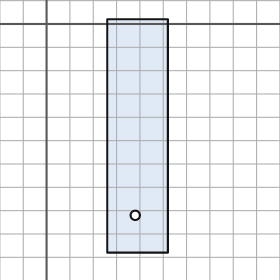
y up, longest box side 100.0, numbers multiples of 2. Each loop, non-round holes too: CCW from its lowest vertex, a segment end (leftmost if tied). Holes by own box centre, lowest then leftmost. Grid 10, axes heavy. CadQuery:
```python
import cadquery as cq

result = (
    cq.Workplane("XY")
    .moveTo(26.0, -98.0)
    .lineTo(52.0, -98.0)
    .lineTo(52.0, 2.0)
    .lineTo(26.0, 2.0)
    .close()
    .moveTo(38.0, -82.0)
    .circle(2.0)
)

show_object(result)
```